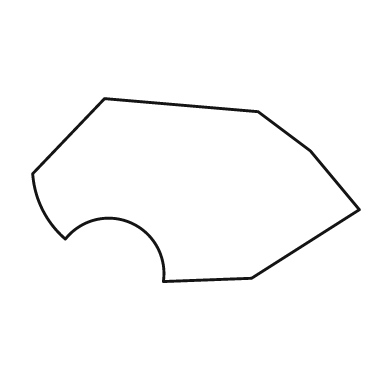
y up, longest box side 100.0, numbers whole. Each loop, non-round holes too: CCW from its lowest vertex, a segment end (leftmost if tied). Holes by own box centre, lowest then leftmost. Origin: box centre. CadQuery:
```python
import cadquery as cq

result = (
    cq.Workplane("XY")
    .moveTo(-10.0, -28.0)
    .lineTo(17.0, -27.0)
    .lineTo(50.0, -6.0)
    .lineTo(35.0, 12.0)
    .lineTo(19.0, 24.0)
    .lineTo(-28.0, 28.0)
    .lineTo(-50.0, 5.0)
    .threePointArc((-47.0, -6.0), (-40.0, -15.0))
    .threePointArc((-20.0, -10.0), (-10.0, -28.0))
    .close()
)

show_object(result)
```